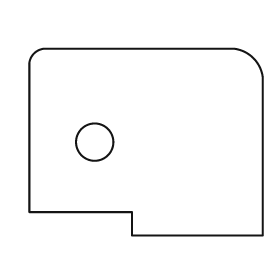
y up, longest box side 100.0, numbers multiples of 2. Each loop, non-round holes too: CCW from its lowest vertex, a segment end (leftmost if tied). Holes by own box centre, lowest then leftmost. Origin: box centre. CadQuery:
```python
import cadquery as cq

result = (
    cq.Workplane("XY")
    .moveTo(-6.0, -40.0)
    .lineTo(50.0, -40.0)
    .lineTo(50.0, 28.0)
    .threePointArc((46.0, 36.0), (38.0, 40.0))
    .lineTo(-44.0, 40.0)
    .threePointArc((-48.0, 38.0), (-50.0, 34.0))
    .lineTo(-50.0, -30.0)
    .lineTo(-6.0, -30.0)
    .close()
    .moveTo(-22.0, 0.0)
    .circle(8.0)
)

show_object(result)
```